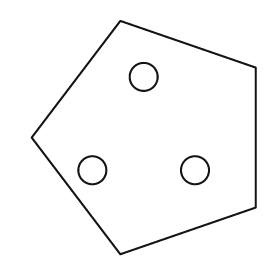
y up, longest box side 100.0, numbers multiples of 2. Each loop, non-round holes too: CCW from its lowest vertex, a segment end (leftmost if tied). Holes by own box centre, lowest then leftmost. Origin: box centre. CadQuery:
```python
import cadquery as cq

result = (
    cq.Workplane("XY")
    .moveTo(-10.0, -50.0)
    .lineTo(48.0, -30.0)
    .lineTo(48.0, 30.0)
    .lineTo(-10.0, 50.0)
    .lineTo(-48.0, 0.0)
    .close()
    .moveTo(-22.0, -14.0)
    .circle(6.0)
    .moveTo(22.0, -14.0)
    .circle(6.0)
    .moveTo(0.0, 26.0)
    .circle(6.0)
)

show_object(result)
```